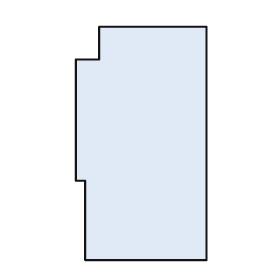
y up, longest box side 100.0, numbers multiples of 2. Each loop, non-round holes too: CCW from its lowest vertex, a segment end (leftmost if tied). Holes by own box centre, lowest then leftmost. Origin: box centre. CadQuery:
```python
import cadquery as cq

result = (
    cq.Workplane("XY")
    .moveTo(-24.0, -50.0)
    .lineTo(28.0, -50.0)
    .lineTo(28.0, 50.0)
    .lineTo(-18.0, 50.0)
    .lineTo(-18.0, 36.0)
    .lineTo(-28.0, 36.0)
    .lineTo(-28.0, -16.0)
    .lineTo(-24.0, -16.0)
    .close()
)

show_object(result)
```